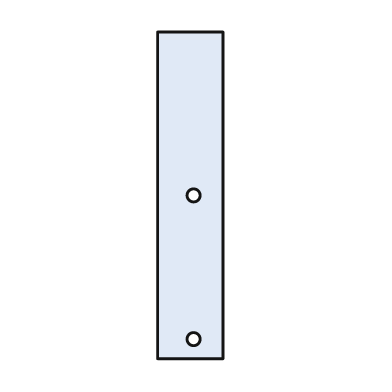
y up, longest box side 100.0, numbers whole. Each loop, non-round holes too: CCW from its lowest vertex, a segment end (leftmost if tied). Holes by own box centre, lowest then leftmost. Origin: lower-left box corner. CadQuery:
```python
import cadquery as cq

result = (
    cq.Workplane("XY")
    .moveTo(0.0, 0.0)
    .lineTo(20.0, 0.0)
    .lineTo(20.0, 100.0)
    .lineTo(0.0, 100.0)
    .close()
    .moveTo(11.0, 6.0)
    .circle(2.0)
    .moveTo(11.0, 50.0)
    .circle(2.0)
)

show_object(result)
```